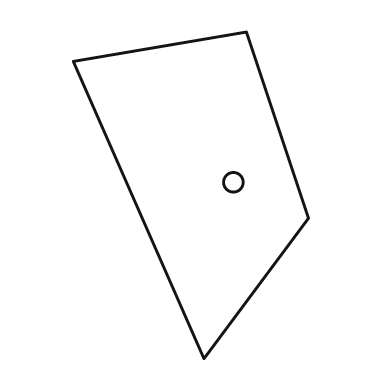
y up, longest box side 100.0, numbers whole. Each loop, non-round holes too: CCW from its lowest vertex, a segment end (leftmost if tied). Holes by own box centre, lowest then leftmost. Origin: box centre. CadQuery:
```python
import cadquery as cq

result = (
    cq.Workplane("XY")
    .moveTo(4.0, -50.0)
    .lineTo(36.0, -7.0)
    .lineTo(17.0, 50.0)
    .lineTo(-36.0, 41.0)
    .close()
    .moveTo(13.0, 4.0)
    .circle(3.0)
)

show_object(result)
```